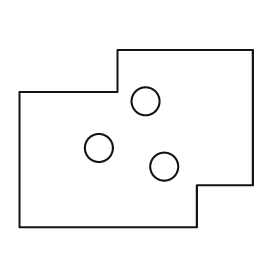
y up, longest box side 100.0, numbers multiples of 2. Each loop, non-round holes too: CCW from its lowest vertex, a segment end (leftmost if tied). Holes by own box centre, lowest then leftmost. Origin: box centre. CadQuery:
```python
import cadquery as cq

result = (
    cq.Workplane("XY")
    .moveTo(-50.0, -38.0)
    .lineTo(26.0, -38.0)
    .lineTo(26.0, -20.0)
    .lineTo(50.0, -20.0)
    .lineTo(50.0, 38.0)
    .lineTo(-8.0, 38.0)
    .lineTo(-8.0, 20.0)
    .lineTo(-50.0, 20.0)
    .close()
    .moveTo(12.0, -12.0)
    .circle(6.0)
    .moveTo(-16.0, -4.0)
    .circle(6.0)
    .moveTo(4.0, 16.0)
    .circle(6.0)
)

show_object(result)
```